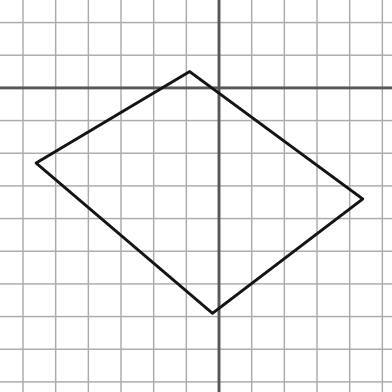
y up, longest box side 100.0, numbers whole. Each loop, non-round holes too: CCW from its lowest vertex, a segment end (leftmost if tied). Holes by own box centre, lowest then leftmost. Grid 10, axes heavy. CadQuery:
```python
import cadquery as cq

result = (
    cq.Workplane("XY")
    .moveTo(-2.0, -69.0)
    .lineTo(44.0, -34.0)
    .lineTo(-9.0, 5.0)
    .lineTo(-56.0, -23.0)
    .close()
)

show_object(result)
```